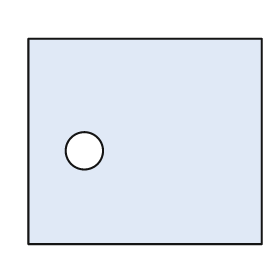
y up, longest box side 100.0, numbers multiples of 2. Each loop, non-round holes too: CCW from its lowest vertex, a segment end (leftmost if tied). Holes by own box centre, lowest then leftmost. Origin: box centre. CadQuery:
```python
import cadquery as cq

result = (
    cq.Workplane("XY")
    .moveTo(-50.0, -44.0)
    .lineTo(50.0, -44.0)
    .lineTo(50.0, 44.0)
    .lineTo(-50.0, 44.0)
    .close()
    .moveTo(-26.0, -4.0)
    .circle(8.0)
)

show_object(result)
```